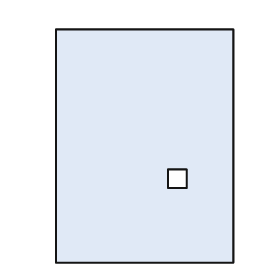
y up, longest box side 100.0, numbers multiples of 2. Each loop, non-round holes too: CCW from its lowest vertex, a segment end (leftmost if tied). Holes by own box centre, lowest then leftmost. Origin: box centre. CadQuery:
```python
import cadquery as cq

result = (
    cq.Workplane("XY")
    .moveTo(-38.0, -50.0)
    .lineTo(38.0, -50.0)
    .lineTo(38.0, 50.0)
    .lineTo(-38.0, 50.0)
    .close()
    .moveTo(10.0, -18.0)
    .lineTo(18.0, -18.0)
    .lineTo(18.0, -10.0)
    .lineTo(10.0, -10.0)
    .close()
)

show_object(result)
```